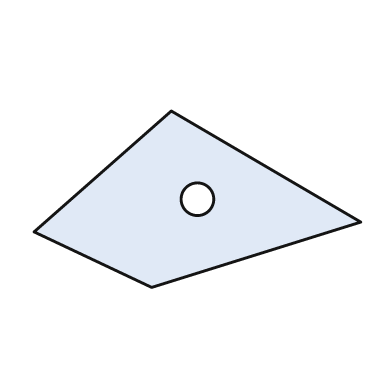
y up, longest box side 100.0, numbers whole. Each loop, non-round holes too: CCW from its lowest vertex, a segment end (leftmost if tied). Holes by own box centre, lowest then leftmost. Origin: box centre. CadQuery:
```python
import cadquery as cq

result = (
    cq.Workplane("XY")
    .moveTo(-14.0, -27.0)
    .lineTo(50.0, -7.0)
    .lineTo(-8.0, 27.0)
    .lineTo(-50.0, -10.0)
    .close()
    .moveTo(0.0, 0.0)
    .circle(5.0)
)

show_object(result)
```